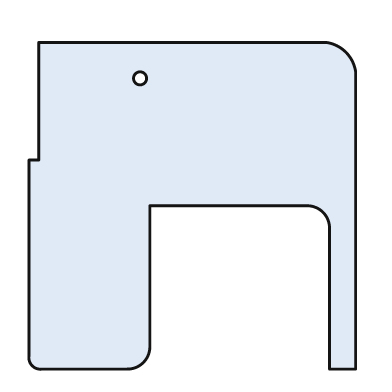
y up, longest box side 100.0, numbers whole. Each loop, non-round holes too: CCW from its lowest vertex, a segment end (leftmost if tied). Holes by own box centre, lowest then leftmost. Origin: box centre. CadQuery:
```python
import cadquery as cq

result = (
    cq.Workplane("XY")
    .moveTo(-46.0, -50.0)
    .lineTo(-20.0, -50.0)
    .threePointArc((-15.0, -48.0), (-13.0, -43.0))
    .lineTo(-13.0, 0.0)
    .lineTo(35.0, 0.0)
    .threePointArc((40.0, -2.0), (42.0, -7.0))
    .lineTo(42.0, -50.0)
    .lineTo(50.0, -50.0)
    .lineTo(50.0, 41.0)
    .threePointArc((47.0, 47.0), (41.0, 50.0))
    .lineTo(-47.0, 50.0)
    .lineTo(-47.0, 14.0)
    .lineTo(-50.0, 14.0)
    .lineTo(-50.0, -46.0)
    .threePointArc((-49.0, -49.0), (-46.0, -50.0))
    .close()
    .moveTo(-16.0, 39.0)
    .circle(2.0)
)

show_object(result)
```